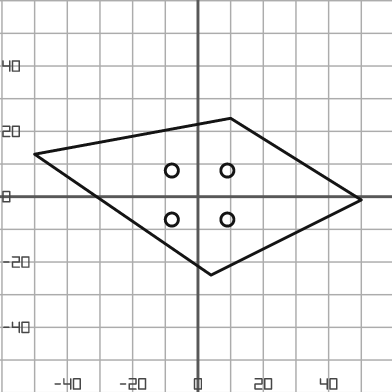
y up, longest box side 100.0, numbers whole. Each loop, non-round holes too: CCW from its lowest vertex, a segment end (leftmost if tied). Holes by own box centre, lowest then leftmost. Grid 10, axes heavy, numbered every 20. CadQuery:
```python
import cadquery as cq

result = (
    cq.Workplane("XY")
    .moveTo(4.0, -24.0)
    .lineTo(50.0, -1.0)
    .lineTo(10.0, 24.0)
    .lineTo(-50.0, 13.0)
    .close()
    .moveTo(-8.0, -7.0)
    .circle(2.0)
    .moveTo(9.0, -7.0)
    .circle(2.0)
    .moveTo(-8.0, 8.0)
    .circle(2.0)
    .moveTo(9.0, 8.0)
    .circle(2.0)
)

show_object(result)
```